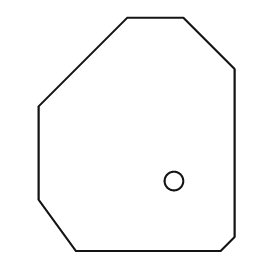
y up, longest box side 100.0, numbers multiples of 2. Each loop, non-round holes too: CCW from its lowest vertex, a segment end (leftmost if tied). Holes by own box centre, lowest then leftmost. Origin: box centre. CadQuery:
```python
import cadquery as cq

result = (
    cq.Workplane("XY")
    .moveTo(-26.0, -50.0)
    .lineTo(36.0, -50.0)
    .lineTo(42.0, -44.0)
    .lineTo(42.0, 28.0)
    .lineTo(20.0, 50.0)
    .lineTo(-4.0, 50.0)
    .lineTo(-42.0, 12.0)
    .lineTo(-42.0, -28.0)
    .close()
    .moveTo(16.0, -20.0)
    .circle(4.0)
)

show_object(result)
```